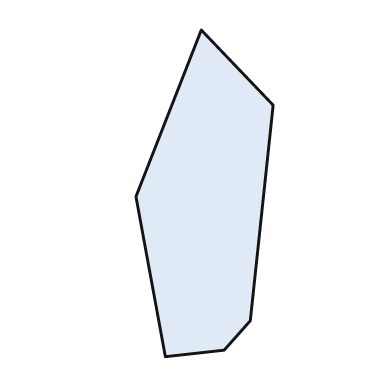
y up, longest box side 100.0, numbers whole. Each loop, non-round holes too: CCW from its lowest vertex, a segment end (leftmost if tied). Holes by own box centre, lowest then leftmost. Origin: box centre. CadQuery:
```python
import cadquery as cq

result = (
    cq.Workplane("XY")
    .moveTo(-12.0, -50.0)
    .lineTo(6.0, -48.0)
    .lineTo(14.0, -39.0)
    .lineTo(21.0, 27.0)
    .lineTo(-1.0, 50.0)
    .lineTo(-21.0, -1.0)
    .close()
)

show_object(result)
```